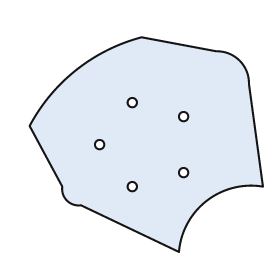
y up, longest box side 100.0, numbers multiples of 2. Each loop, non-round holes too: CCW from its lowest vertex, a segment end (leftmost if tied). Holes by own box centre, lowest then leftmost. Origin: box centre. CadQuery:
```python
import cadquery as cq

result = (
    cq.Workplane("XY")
    .moveTo(14.0, -46.0)
    .threePointArc((26.0, -24.0), (50.0, -18.0))
    .lineTo(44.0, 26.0)
    .threePointArc((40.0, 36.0), (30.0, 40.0))
    .lineTo(-2.0, 46.0)
    .threePointArc((-30.0, 32.0), (-50.0, 8.0))
    .lineTo(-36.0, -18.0)
    .threePointArc((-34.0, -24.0), (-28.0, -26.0))
    .close()
    .moveTo(-6.0, -18.0)
    .circle(2.0)
    .moveTo(16.0, -12.0)
    .circle(2.0)
    .moveTo(-20.0, 0.0)
    .circle(2.0)
    .moveTo(16.0, 12.0)
    .circle(2.0)
    .moveTo(-6.0, 18.0)
    .circle(2.0)
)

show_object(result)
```